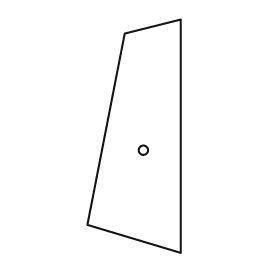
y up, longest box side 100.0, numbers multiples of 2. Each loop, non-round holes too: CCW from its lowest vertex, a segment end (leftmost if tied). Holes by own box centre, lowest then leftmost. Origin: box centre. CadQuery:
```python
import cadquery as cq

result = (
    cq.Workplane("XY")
    .moveTo(20.0, -50.0)
    .lineTo(20.0, 50.0)
    .lineTo(-4.0, 44.0)
    .lineTo(-20.0, -38.0)
    .close()
    .moveTo(4.0, -6.0)
    .circle(2.0)
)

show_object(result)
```